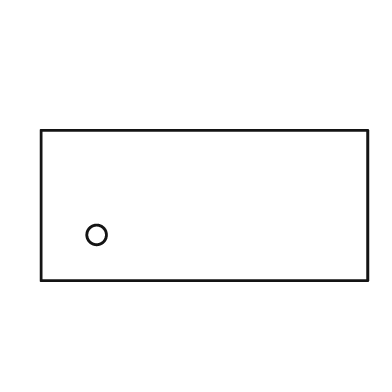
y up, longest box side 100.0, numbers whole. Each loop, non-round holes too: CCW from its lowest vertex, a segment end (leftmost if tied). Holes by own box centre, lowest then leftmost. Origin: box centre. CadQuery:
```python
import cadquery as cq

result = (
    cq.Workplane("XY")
    .moveTo(-50.0, -23.0)
    .lineTo(50.0, -23.0)
    .lineTo(50.0, 23.0)
    .lineTo(-50.0, 23.0)
    .close()
    .moveTo(-33.0, -9.0)
    .circle(3.0)
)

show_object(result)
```